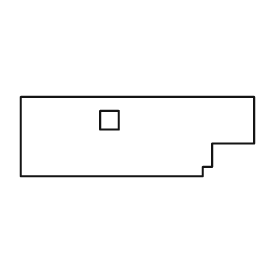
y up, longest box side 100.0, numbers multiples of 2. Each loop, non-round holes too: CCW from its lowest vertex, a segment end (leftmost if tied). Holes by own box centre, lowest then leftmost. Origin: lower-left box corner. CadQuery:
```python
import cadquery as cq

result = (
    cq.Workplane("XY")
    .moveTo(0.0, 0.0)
    .lineTo(78.0, 0.0)
    .lineTo(78.0, 4.0)
    .lineTo(82.0, 4.0)
    .lineTo(82.0, 14.0)
    .lineTo(100.0, 14.0)
    .lineTo(100.0, 34.0)
    .lineTo(0.0, 34.0)
    .close()
    .moveTo(34.0, 20.0)
    .lineTo(42.0, 20.0)
    .lineTo(42.0, 28.0)
    .lineTo(34.0, 28.0)
    .close()
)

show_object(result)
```